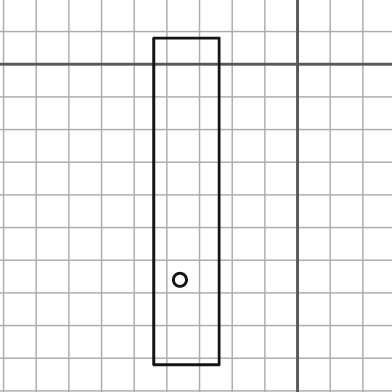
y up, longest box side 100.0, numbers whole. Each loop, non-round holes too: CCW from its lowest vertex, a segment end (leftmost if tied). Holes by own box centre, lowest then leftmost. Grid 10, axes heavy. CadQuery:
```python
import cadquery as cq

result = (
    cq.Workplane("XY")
    .moveTo(-44.0, -92.0)
    .lineTo(-24.0, -92.0)
    .lineTo(-24.0, 8.0)
    .lineTo(-44.0, 8.0)
    .close()
    .moveTo(-36.0, -66.0)
    .circle(2.0)
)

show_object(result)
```